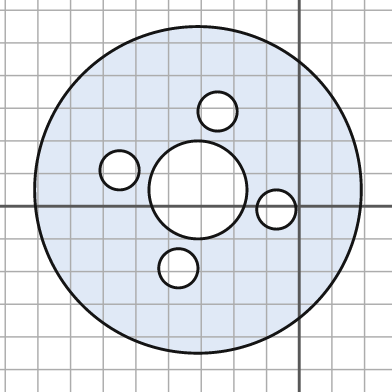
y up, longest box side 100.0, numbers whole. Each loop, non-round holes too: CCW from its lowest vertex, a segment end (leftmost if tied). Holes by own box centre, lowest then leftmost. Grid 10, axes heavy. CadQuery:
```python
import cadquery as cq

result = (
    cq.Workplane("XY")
    .moveTo(-31.0, 5.0)
    .circle(50.0)
    .moveTo(-37.0, -19.0)
    .circle(6.0)
    .moveTo(-7.0, -1.0)
    .circle(6.0)
    .moveTo(-31.0, 5.0)
    .circle(15.0)
    .moveTo(-55.0, 11.0)
    .circle(6.0)
    .moveTo(-25.0, 29.0)
    .circle(6.0)
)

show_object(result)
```